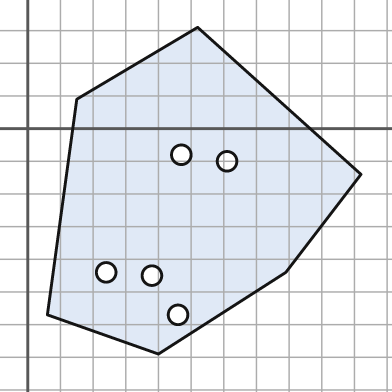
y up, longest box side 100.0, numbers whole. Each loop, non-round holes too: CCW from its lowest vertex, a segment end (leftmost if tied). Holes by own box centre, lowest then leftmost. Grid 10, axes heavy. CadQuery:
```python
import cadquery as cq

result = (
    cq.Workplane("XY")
    .moveTo(40.0, -69.0)
    .lineTo(79.0, -44.0)
    .lineTo(102.0, -14.0)
    .lineTo(52.0, 31.0)
    .lineTo(15.0, 9.0)
    .lineTo(6.0, -57.0)
    .close()
    .moveTo(46.0, -57.0)
    .circle(3.0)
    .moveTo(38.0, -45.0)
    .circle(3.0)
    .moveTo(24.0, -44.0)
    .circle(3.0)
    .moveTo(61.0, -10.0)
    .circle(3.0)
    .moveTo(47.0, -8.0)
    .circle(3.0)
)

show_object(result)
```